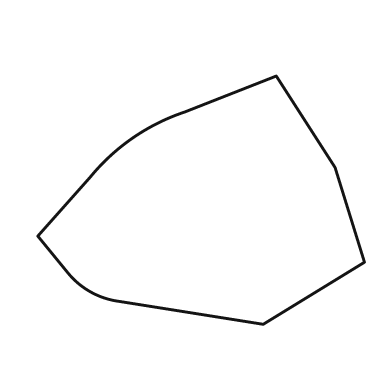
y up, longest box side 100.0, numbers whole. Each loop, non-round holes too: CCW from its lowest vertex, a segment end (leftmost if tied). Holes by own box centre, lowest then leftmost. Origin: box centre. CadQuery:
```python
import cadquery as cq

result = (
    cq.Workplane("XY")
    .moveTo(19.0, -38.0)
    .lineTo(50.0, -19.0)
    .lineTo(41.0, 10.0)
    .lineTo(23.0, 38.0)
    .lineTo(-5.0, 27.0)
    .threePointArc((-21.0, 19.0), (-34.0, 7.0))
    .lineTo(-50.0, -11.0)
    .lineTo(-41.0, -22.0)
    .threePointArc((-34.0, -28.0), (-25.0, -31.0))
    .close()
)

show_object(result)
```